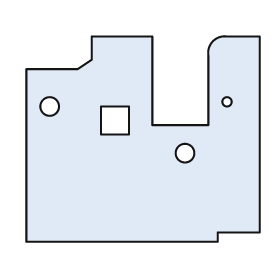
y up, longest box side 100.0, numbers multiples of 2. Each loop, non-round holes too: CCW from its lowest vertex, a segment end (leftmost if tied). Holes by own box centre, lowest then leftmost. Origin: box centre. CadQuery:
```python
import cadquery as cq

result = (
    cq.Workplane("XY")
    .moveTo(-50.0, -44.0)
    .lineTo(32.0, -44.0)
    .lineTo(32.0, -40.0)
    .lineTo(50.0, -40.0)
    .lineTo(50.0, 44.0)
    .lineTo(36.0, 44.0)
    .threePointArc((30.0, 42.0), (28.0, 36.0))
    .lineTo(28.0, 6.0)
    .lineTo(4.0, 6.0)
    .lineTo(4.0, 44.0)
    .lineTo(-22.0, 44.0)
    .lineTo(-22.0, 34.0)
    .lineTo(-28.0, 30.0)
    .lineTo(-50.0, 30.0)
    .close()
    .moveTo(18.0, -6.0)
    .circle(4.0)
    .moveTo(-18.0, 2.0)
    .lineTo(-6.0, 2.0)
    .lineTo(-6.0, 14.0)
    .lineTo(-18.0, 14.0)
    .close()
    .moveTo(-40.0, 14.0)
    .circle(4.0)
    .moveTo(36.0, 16.0)
    .circle(2.0)
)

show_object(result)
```